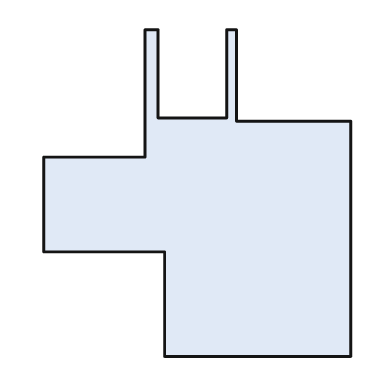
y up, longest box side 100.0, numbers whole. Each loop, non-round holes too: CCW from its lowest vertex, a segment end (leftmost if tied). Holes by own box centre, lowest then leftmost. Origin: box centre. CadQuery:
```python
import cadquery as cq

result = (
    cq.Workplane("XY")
    .moveTo(-10.0, -50.0)
    .lineTo(47.0, -50.0)
    .lineTo(47.0, 22.0)
    .lineTo(12.0, 22.0)
    .lineTo(12.0, 50.0)
    .lineTo(9.0, 50.0)
    .lineTo(9.0, 23.0)
    .lineTo(-12.0, 23.0)
    .lineTo(-12.0, 50.0)
    .lineTo(-16.0, 50.0)
    .lineTo(-16.0, 11.0)
    .lineTo(-47.0, 11.0)
    .lineTo(-47.0, -18.0)
    .lineTo(-10.0, -18.0)
    .close()
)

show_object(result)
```